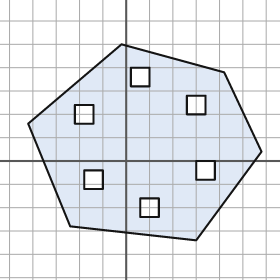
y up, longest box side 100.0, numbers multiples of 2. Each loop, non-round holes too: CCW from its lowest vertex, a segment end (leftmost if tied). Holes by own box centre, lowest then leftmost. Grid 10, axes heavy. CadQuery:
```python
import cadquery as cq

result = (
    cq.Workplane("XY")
    .moveTo(30.0, -34.0)
    .lineTo(58.0, 4.0)
    .lineTo(42.0, 38.0)
    .lineTo(-2.0, 50.0)
    .lineTo(-42.0, 16.0)
    .lineTo(-24.0, -28.0)
    .close()
    .moveTo(6.0, -24.0)
    .lineTo(14.0, -24.0)
    .lineTo(14.0, -16.0)
    .lineTo(6.0, -16.0)
    .close()
    .moveTo(-18.0, -12.0)
    .lineTo(-10.0, -12.0)
    .lineTo(-10.0, -4.0)
    .lineTo(-18.0, -4.0)
    .close()
    .moveTo(30.0, -8.0)
    .lineTo(38.0, -8.0)
    .lineTo(38.0, 0.0)
    .lineTo(30.0, 0.0)
    .close()
    .moveTo(-22.0, 16.0)
    .lineTo(-14.0, 16.0)
    .lineTo(-14.0, 24.0)
    .lineTo(-22.0, 24.0)
    .close()
    .moveTo(26.0, 20.0)
    .lineTo(34.0, 20.0)
    .lineTo(34.0, 28.0)
    .lineTo(26.0, 28.0)
    .close()
    .moveTo(2.0, 32.0)
    .lineTo(10.0, 32.0)
    .lineTo(10.0, 40.0)
    .lineTo(2.0, 40.0)
    .close()
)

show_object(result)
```